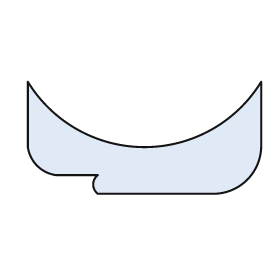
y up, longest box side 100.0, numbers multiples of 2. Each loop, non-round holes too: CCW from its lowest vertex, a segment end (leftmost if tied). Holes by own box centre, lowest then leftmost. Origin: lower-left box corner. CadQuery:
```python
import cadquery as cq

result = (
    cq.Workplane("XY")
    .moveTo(30.0, 0.0)
    .lineTo(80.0, 0.0)
    .threePointArc((94.0, 6.0), (100.0, 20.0))
    .lineTo(100.0, 48.0)
    .threePointArc((50.0, 20.0), (0.0, 48.0))
    .lineTo(0.0, 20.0)
    .threePointArc((4.0, 12.0), (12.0, 8.0))
    .lineTo(30.0, 8.0)
    .threePointArc((28.0, 4.0), (30.0, 0.0))
    .close()
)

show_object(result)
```